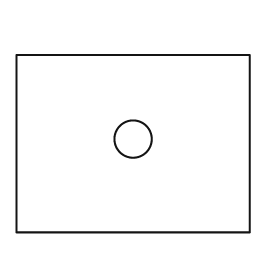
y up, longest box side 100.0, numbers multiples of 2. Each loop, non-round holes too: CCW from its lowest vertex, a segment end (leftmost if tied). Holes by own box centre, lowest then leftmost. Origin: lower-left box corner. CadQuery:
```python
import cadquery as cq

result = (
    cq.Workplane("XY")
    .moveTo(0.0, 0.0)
    .lineTo(100.0, 0.0)
    .lineTo(100.0, 76.0)
    .lineTo(0.0, 76.0)
    .close()
    .moveTo(50.0, 40.0)
    .circle(8.0)
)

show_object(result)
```